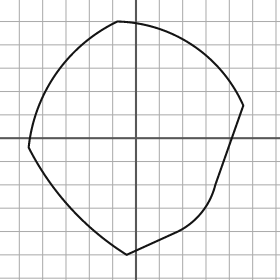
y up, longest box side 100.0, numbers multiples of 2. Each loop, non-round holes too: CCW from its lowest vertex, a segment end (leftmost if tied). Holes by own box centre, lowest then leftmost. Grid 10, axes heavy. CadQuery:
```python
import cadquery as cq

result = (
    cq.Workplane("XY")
    .moveTo(-4.0, -50.0)
    .lineTo(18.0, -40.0)
    .threePointArc((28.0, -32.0), (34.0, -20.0))
    .lineTo(46.0, 14.0)
    .threePointArc((24.0, 40.0), (-8.0, 50.0))
    .threePointArc((-34.0, 28.0), (-46.0, -4.0))
    .threePointArc((-28.0, -30.0), (-4.0, -50.0))
    .close()
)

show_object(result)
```